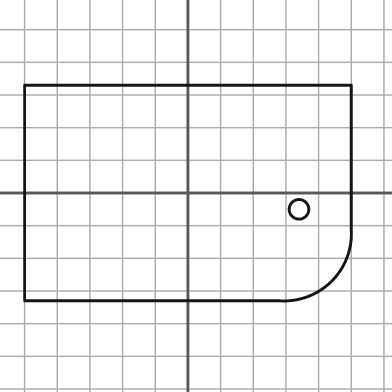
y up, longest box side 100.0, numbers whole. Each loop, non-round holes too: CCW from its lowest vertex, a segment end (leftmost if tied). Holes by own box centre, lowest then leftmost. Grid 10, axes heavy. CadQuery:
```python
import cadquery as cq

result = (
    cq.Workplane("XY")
    .moveTo(-50.0, -33.0)
    .lineTo(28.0, -33.0)
    .threePointArc((44.0, -27.0), (50.0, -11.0))
    .lineTo(50.0, 33.0)
    .lineTo(-50.0, 33.0)
    .close()
    .moveTo(34.0, -5.0)
    .circle(3.0)
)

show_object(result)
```